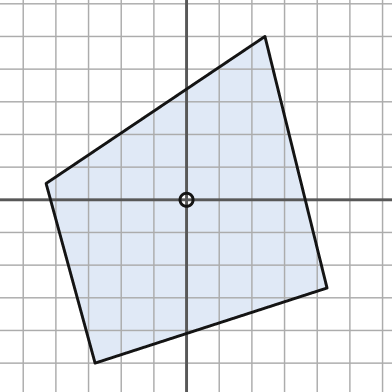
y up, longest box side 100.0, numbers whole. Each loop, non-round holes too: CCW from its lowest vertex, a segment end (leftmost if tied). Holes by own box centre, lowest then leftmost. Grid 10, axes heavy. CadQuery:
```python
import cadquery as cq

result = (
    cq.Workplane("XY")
    .moveTo(-28.0, -50.0)
    .lineTo(43.0, -27.0)
    .lineTo(24.0, 50.0)
    .lineTo(-43.0, 5.0)
    .close()
    .moveTo(0.0, 0.0)
    .circle(2.0)
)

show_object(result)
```